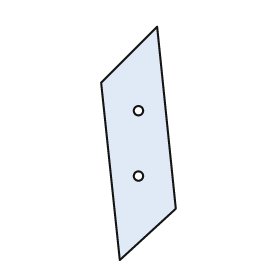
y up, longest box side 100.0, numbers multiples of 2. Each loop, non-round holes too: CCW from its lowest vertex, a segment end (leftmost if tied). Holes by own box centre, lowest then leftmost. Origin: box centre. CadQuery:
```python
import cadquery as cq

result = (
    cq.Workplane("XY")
    .moveTo(-8.0, -50.0)
    .lineTo(16.0, -28.0)
    .lineTo(8.0, 50.0)
    .lineTo(-16.0, 26.0)
    .close()
    .moveTo(0.0, -14.0)
    .circle(2.0)
    .moveTo(0.0, 14.0)
    .circle(2.0)
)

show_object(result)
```